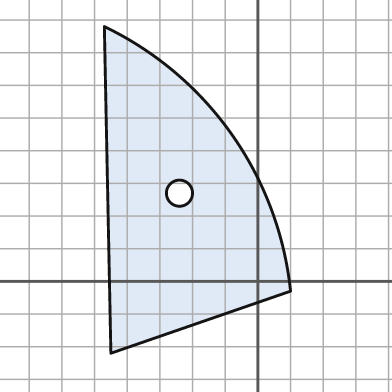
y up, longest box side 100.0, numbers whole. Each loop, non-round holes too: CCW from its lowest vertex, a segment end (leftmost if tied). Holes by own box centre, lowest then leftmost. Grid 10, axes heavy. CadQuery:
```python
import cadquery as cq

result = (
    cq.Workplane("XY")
    .moveTo(-45.0, -22.0)
    .lineTo(10.0, -3.0)
    .threePointArc((-8.0, 45.0), (-47.0, 78.0))
    .close()
    .moveTo(-24.0, 27.0)
    .circle(4.0)
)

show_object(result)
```